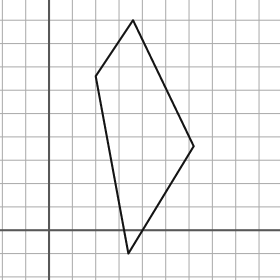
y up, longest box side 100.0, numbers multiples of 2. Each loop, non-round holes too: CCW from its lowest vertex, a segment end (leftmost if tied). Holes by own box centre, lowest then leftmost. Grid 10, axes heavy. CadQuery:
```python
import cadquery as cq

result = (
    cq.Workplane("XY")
    .moveTo(34.0, -10.0)
    .lineTo(62.0, 36.0)
    .lineTo(36.0, 90.0)
    .lineTo(20.0, 66.0)
    .close()
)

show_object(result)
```